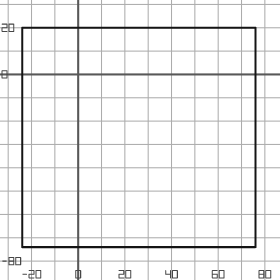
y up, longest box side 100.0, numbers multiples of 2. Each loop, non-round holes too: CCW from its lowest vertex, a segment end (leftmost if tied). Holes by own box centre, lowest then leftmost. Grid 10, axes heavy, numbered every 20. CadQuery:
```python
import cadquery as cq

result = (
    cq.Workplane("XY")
    .moveTo(-24.0, -74.0)
    .lineTo(76.0, -74.0)
    .lineTo(76.0, 20.0)
    .lineTo(-24.0, 20.0)
    .close()
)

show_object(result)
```